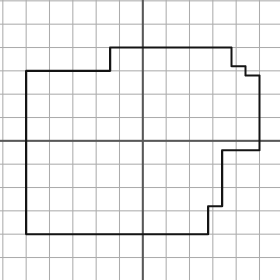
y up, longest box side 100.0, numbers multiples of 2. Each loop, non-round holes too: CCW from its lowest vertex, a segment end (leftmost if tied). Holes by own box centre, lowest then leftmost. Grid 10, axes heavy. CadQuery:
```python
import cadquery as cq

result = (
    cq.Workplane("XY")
    .moveTo(-50.0, -40.0)
    .lineTo(28.0, -40.0)
    .lineTo(28.0, -28.0)
    .lineTo(34.0, -28.0)
    .lineTo(34.0, -4.0)
    .lineTo(50.0, -4.0)
    .lineTo(50.0, 28.0)
    .lineTo(44.0, 28.0)
    .lineTo(44.0, 32.0)
    .lineTo(38.0, 32.0)
    .lineTo(38.0, 40.0)
    .lineTo(-14.0, 40.0)
    .lineTo(-14.0, 30.0)
    .lineTo(-50.0, 30.0)
    .close()
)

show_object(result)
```